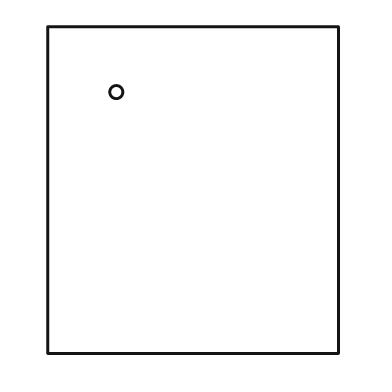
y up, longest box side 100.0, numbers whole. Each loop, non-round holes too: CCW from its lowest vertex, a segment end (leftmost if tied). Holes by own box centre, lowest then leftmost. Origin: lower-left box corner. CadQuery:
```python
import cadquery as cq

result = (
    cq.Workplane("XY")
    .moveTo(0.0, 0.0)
    .lineTo(89.0, 0.0)
    .lineTo(89.0, 100.0)
    .lineTo(0.0, 100.0)
    .close()
    .moveTo(21.0, 80.0)
    .circle(2.0)
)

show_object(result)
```